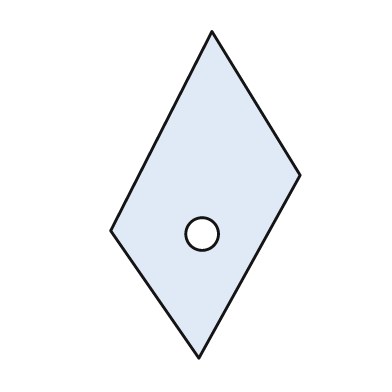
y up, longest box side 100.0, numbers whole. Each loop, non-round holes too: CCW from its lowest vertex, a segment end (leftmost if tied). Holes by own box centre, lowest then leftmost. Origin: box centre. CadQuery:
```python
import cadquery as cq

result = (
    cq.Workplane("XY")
    .moveTo(-2.0, -50.0)
    .lineTo(29.0, 6.0)
    .lineTo(2.0, 50.0)
    .lineTo(-29.0, -11.0)
    .close()
    .moveTo(-1.0, -12.0)
    .circle(5.0)
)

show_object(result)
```